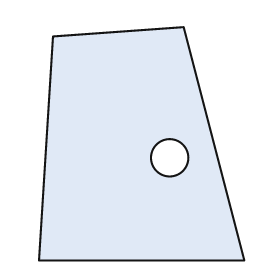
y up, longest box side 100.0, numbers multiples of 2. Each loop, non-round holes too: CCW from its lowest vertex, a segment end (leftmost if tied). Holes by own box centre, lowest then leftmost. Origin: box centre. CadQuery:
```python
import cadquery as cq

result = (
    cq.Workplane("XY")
    .moveTo(-44.0, -50.0)
    .lineTo(44.0, -50.0)
    .lineTo(18.0, 50.0)
    .lineTo(-38.0, 46.0)
    .close()
    .moveTo(12.0, -6.0)
    .circle(8.0)
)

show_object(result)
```